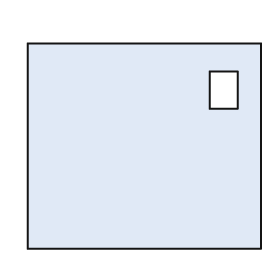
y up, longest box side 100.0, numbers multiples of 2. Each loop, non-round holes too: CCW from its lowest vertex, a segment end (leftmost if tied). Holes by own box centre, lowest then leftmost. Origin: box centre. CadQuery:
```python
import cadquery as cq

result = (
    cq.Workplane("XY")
    .moveTo(-50.0, -44.0)
    .lineTo(50.0, -44.0)
    .lineTo(50.0, 44.0)
    .lineTo(-50.0, 44.0)
    .close()
    .moveTo(28.0, 16.0)
    .lineTo(40.0, 16.0)
    .lineTo(40.0, 32.0)
    .lineTo(28.0, 32.0)
    .close()
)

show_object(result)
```